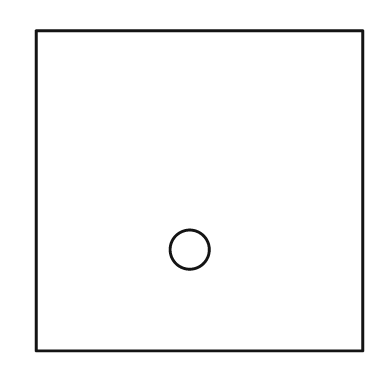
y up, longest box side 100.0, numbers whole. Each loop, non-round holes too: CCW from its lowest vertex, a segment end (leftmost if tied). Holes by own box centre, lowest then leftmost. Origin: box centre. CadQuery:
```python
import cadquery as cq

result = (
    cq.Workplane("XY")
    .moveTo(-50.0, -49.0)
    .lineTo(50.0, -49.0)
    .lineTo(50.0, 49.0)
    .lineTo(-50.0, 49.0)
    .close()
    .moveTo(-3.0, -18.0)
    .circle(6.0)
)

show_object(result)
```